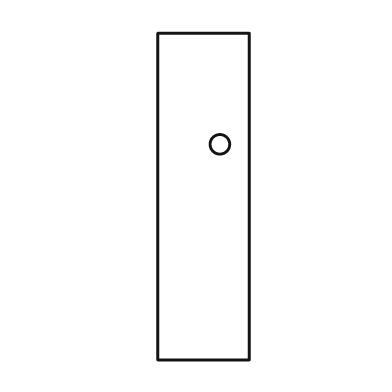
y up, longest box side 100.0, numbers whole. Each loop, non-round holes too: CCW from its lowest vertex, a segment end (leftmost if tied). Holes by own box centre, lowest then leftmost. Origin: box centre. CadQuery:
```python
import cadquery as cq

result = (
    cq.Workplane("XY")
    .moveTo(-14.0, -50.0)
    .lineTo(14.0, -50.0)
    .lineTo(14.0, 50.0)
    .lineTo(-14.0, 50.0)
    .close()
    .moveTo(5.0, 16.0)
    .circle(3.0)
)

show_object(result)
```